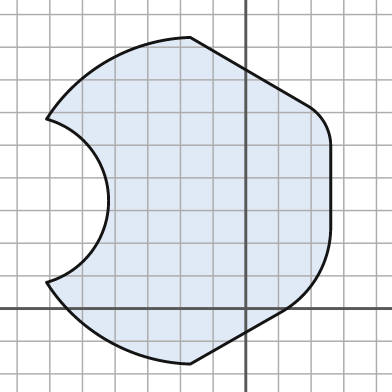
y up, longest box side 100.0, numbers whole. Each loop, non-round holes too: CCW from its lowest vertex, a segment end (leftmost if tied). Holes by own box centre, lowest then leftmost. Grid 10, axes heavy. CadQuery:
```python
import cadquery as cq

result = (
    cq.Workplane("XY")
    .moveTo(-17.0, -17.0)
    .lineTo(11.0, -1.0)
    .threePointArc((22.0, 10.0), (26.0, 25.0))
    .lineTo(26.0, 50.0)
    .threePointArc((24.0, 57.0), (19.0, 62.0))
    .lineTo(-17.0, 83.0)
    .threePointArc((-42.0, 76.0), (-61.0, 58.0))
    .threePointArc((-42.0, 33.0), (-61.0, 8.0))
    .threePointArc((-42.0, -10.0), (-17.0, -17.0))
    .close()
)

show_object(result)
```